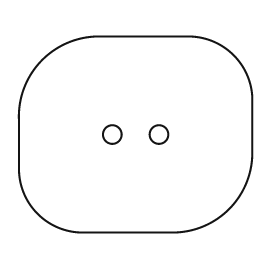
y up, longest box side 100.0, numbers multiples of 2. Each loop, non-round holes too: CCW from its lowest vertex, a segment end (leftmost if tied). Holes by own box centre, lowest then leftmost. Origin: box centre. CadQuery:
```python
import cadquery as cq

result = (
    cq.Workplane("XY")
    .moveTo(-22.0, -42.0)
    .lineTo(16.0, -42.0)
    .threePointArc((40.0, -32.0), (50.0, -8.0))
    .lineTo(50.0, 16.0)
    .threePointArc((42.0, 34.0), (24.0, 42.0))
    .lineTo(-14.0, 42.0)
    .threePointArc((-40.0, 32.0), (-50.0, 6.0))
    .lineTo(-50.0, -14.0)
    .threePointArc((-42.0, -34.0), (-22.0, -42.0))
    .close()
    .moveTo(-10.0, 0.0)
    .circle(4.0)
    .moveTo(10.0, 0.0)
    .circle(4.0)
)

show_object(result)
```